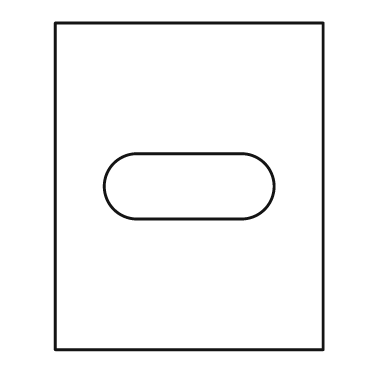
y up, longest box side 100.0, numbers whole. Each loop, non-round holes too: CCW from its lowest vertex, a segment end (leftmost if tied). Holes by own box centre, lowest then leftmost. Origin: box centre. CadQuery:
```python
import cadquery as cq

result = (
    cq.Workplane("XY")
    .moveTo(-41.0, -50.0)
    .lineTo(41.0, -50.0)
    .lineTo(41.0, 50.0)
    .lineTo(-41.0, 50.0)
    .close()
    .moveTo(-16.0, -10.0)
    .lineTo(16.0, -10.0)
    .threePointArc((26.0, 0.0), (16.0, 10.0))
    .lineTo(-16.0, 10.0)
    .threePointArc((-26.0, 0.0), (-16.0, -10.0))
    .close()
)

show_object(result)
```